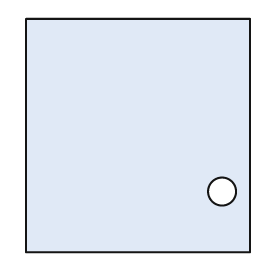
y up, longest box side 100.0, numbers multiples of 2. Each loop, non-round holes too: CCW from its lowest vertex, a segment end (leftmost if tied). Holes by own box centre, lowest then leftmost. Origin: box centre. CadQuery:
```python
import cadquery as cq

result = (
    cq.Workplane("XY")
    .moveTo(-48.0, -50.0)
    .lineTo(48.0, -50.0)
    .lineTo(48.0, 50.0)
    .lineTo(-48.0, 50.0)
    .close()
    .moveTo(36.0, -24.0)
    .circle(6.0)
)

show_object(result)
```